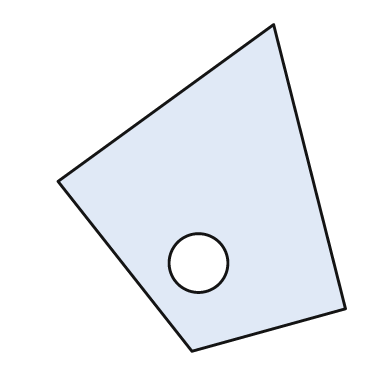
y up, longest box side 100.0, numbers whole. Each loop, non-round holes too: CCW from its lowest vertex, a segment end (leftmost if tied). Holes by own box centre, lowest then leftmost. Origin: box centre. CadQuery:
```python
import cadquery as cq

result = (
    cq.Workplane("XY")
    .moveTo(-3.0, -50.0)
    .lineTo(44.0, -37.0)
    .lineTo(22.0, 50.0)
    .lineTo(-44.0, 2.0)
    .close()
    .moveTo(-1.0, -23.0)
    .circle(9.0)
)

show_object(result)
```